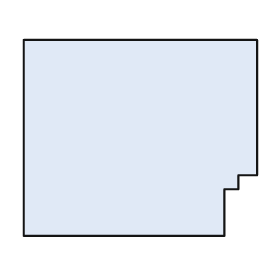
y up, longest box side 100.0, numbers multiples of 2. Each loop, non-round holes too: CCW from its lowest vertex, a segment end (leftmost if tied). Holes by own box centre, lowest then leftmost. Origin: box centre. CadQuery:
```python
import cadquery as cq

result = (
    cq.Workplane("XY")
    .moveTo(-50.0, -42.0)
    .lineTo(36.0, -42.0)
    .lineTo(36.0, -22.0)
    .lineTo(42.0, -22.0)
    .lineTo(42.0, -16.0)
    .lineTo(50.0, -16.0)
    .lineTo(50.0, 42.0)
    .lineTo(-50.0, 42.0)
    .close()
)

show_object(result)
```